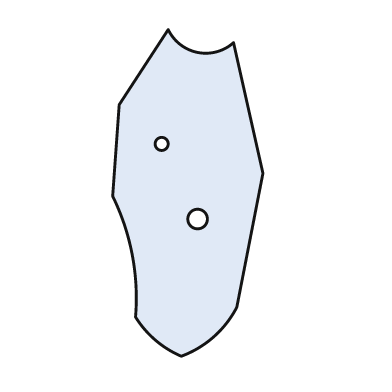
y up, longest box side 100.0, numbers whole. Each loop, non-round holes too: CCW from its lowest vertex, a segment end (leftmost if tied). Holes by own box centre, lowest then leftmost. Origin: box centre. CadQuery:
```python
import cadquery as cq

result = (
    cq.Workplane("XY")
    .moveTo(-2.0, -50.0)
    .threePointArc((8.0, -44.0), (15.0, -35.0))
    .lineTo(23.0, 6.0)
    .lineTo(14.0, 46.0)
    .threePointArc((3.0, 43.0), (-6.0, 50.0))
    .lineTo(-21.0, 27.0)
    .lineTo(-23.0, -1.0)
    .threePointArc((-17.0, -19.0), (-16.0, -38.0))
    .threePointArc((-10.0, -45.0), (-2.0, -50.0))
    .close()
    .moveTo(3.0, -8.0)
    .circle(3.0)
    .moveTo(-8.0, 15.0)
    .circle(2.0)
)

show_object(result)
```